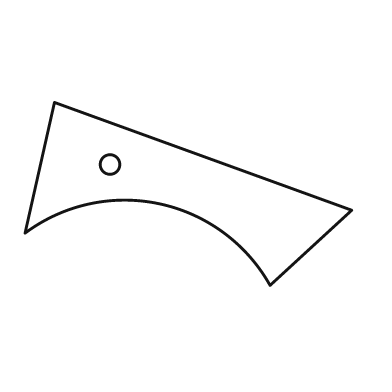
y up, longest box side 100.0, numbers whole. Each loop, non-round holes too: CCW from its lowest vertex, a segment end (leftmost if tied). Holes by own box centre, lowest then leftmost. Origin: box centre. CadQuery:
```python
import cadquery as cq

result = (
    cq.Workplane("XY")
    .moveTo(25.0, -28.0)
    .lineTo(50.0, -5.0)
    .lineTo(-41.0, 28.0)
    .lineTo(-50.0, -12.0)
    .threePointArc((-9.0, -3.0), (25.0, -28.0))
    .close()
    .moveTo(-24.0, 9.0)
    .circle(3.0)
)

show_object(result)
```